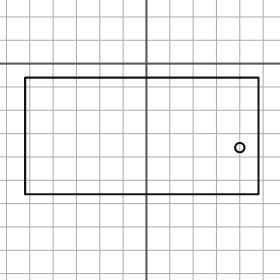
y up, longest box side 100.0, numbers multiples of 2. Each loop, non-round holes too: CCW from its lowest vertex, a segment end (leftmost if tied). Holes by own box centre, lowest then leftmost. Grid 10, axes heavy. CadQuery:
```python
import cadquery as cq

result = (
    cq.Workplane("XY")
    .moveTo(-52.0, -56.0)
    .lineTo(48.0, -56.0)
    .lineTo(48.0, -6.0)
    .lineTo(-52.0, -6.0)
    .close()
    .moveTo(40.0, -36.0)
    .circle(2.0)
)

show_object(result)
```